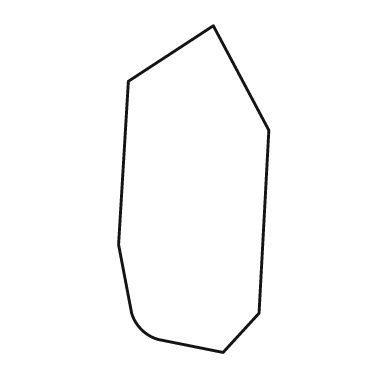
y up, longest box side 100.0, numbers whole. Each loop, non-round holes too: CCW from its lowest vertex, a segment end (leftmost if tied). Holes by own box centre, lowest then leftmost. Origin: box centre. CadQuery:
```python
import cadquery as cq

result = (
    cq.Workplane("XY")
    .moveTo(9.0, -50.0)
    .lineTo(20.0, -38.0)
    .lineTo(23.0, 18.0)
    .lineTo(6.0, 50.0)
    .lineTo(-20.0, 33.0)
    .lineTo(-23.0, -17.0)
    .lineTo(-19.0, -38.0)
    .threePointArc((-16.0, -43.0), (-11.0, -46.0))
    .close()
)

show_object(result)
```